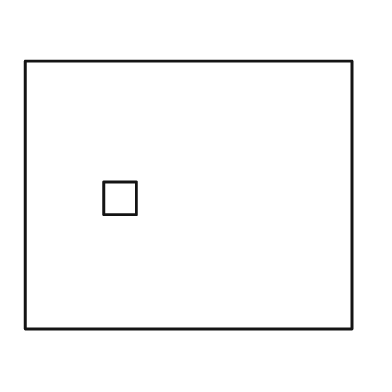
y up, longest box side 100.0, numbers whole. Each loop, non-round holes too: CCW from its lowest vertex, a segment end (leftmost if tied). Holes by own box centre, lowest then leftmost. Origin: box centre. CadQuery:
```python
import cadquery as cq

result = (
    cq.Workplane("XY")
    .moveTo(-50.0, -41.0)
    .lineTo(50.0, -41.0)
    .lineTo(50.0, 41.0)
    .lineTo(-50.0, 41.0)
    .close()
    .moveTo(-26.0, -6.0)
    .lineTo(-16.0, -6.0)
    .lineTo(-16.0, 4.0)
    .lineTo(-26.0, 4.0)
    .close()
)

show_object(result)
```